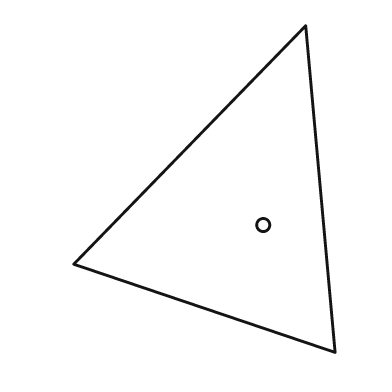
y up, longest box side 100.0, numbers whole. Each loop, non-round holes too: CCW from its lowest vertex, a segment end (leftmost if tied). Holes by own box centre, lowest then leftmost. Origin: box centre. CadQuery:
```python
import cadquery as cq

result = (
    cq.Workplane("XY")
    .moveTo(40.0, -50.0)
    .lineTo(31.0, 50.0)
    .lineTo(-40.0, -23.0)
    .close()
    .moveTo(18.0, -11.0)
    .circle(2.0)
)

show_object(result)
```